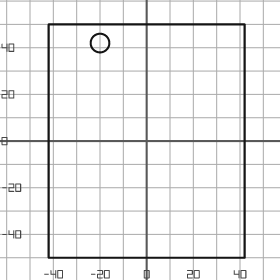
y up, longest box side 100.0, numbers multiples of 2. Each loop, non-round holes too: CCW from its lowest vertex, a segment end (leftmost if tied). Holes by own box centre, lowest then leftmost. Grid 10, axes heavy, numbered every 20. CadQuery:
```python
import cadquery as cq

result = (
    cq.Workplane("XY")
    .moveTo(-42.0, -50.0)
    .lineTo(42.0, -50.0)
    .lineTo(42.0, 50.0)
    .lineTo(-42.0, 50.0)
    .close()
    .moveTo(-20.0, 42.0)
    .circle(4.0)
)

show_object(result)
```